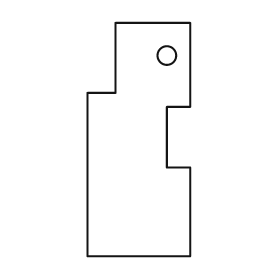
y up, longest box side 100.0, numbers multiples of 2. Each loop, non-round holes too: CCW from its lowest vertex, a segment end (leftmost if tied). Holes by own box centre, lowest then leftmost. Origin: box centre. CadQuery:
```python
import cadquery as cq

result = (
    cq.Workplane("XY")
    .moveTo(-22.0, -50.0)
    .lineTo(22.0, -50.0)
    .lineTo(22.0, -12.0)
    .lineTo(12.0, -12.0)
    .lineTo(12.0, 14.0)
    .lineTo(22.0, 14.0)
    .lineTo(22.0, 50.0)
    .lineTo(-10.0, 50.0)
    .lineTo(-10.0, 20.0)
    .lineTo(-22.0, 20.0)
    .close()
    .moveTo(12.0, 36.0)
    .circle(4.0)
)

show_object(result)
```